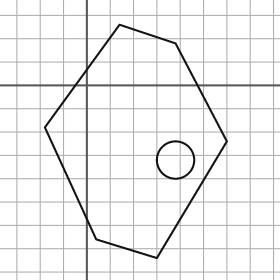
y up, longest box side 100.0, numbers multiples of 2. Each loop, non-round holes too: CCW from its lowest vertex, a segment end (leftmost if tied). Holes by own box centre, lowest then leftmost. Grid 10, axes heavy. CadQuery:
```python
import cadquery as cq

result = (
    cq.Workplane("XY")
    .moveTo(30.0, -74.0)
    .lineTo(60.0, -24.0)
    .lineTo(38.0, 18.0)
    .lineTo(14.0, 26.0)
    .lineTo(-18.0, -18.0)
    .lineTo(4.0, -66.0)
    .close()
    .moveTo(38.0, -32.0)
    .circle(8.0)
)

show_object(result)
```